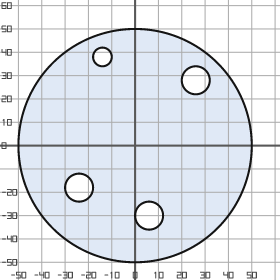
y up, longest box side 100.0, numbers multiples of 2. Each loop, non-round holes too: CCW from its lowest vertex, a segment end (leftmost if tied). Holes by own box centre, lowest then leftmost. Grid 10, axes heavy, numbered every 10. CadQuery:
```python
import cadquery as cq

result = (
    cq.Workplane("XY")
    .moveTo(0.0, 0.0)
    .circle(50.0)
    .moveTo(6.0, -30.0)
    .circle(6.0)
    .moveTo(-24.0, -18.0)
    .circle(6.0)
    .moveTo(26.0, 28.0)
    .circle(6.0)
    .moveTo(-14.0, 38.0)
    .circle(4.0)
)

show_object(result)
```